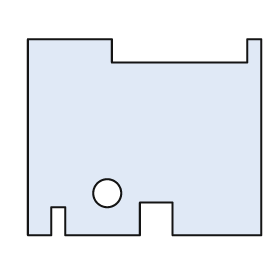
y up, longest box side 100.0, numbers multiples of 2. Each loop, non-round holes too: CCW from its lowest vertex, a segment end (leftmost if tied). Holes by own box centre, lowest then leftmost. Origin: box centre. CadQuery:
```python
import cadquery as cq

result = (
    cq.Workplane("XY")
    .moveTo(-50.0, -42.0)
    .lineTo(-40.0, -42.0)
    .lineTo(-40.0, -30.0)
    .lineTo(-34.0, -30.0)
    .lineTo(-34.0, -42.0)
    .lineTo(-2.0, -42.0)
    .lineTo(-2.0, -28.0)
    .lineTo(12.0, -28.0)
    .lineTo(12.0, -42.0)
    .lineTo(50.0, -42.0)
    .lineTo(50.0, 42.0)
    .lineTo(44.0, 42.0)
    .lineTo(44.0, 32.0)
    .lineTo(-14.0, 32.0)
    .lineTo(-14.0, 42.0)
    .lineTo(-50.0, 42.0)
    .close()
    .moveTo(-16.0, -24.0)
    .circle(6.0)
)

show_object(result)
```